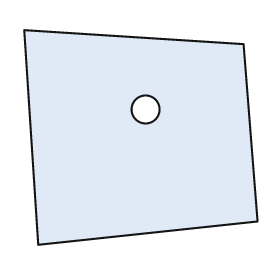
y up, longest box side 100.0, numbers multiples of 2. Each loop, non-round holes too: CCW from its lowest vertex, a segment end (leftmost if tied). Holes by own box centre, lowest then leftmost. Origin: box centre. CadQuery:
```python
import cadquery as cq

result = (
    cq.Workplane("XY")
    .moveTo(-44.0, -46.0)
    .lineTo(50.0, -36.0)
    .lineTo(44.0, 40.0)
    .lineTo(-50.0, 46.0)
    .close()
    .moveTo(2.0, 12.0)
    .circle(6.0)
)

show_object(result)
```